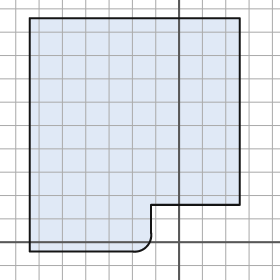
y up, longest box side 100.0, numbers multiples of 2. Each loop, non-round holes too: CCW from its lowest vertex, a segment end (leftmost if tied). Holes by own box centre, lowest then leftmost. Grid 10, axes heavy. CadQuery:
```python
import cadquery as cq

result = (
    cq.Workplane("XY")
    .moveTo(-64.0, -4.0)
    .lineTo(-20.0, -4.0)
    .threePointArc((-14.0, -2.0), (-12.0, 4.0))
    .lineTo(-12.0, 16.0)
    .lineTo(26.0, 16.0)
    .lineTo(26.0, 96.0)
    .lineTo(-64.0, 96.0)
    .close()
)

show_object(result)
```